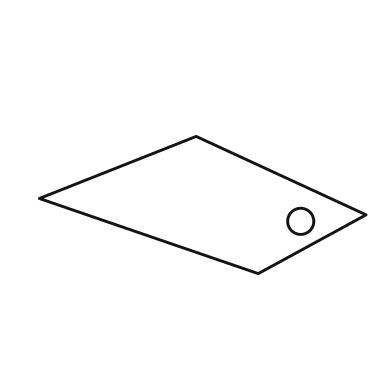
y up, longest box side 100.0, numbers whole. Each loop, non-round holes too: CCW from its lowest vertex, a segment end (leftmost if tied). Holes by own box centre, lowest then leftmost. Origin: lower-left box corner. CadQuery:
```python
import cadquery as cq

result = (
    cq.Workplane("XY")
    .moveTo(67.0, 0.0)
    .lineTo(100.0, 18.0)
    .lineTo(48.0, 42.0)
    .lineTo(0.0, 23.0)
    .close()
    .moveTo(80.0, 16.0)
    .circle(4.0)
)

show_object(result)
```